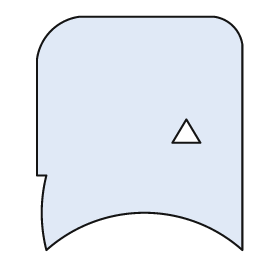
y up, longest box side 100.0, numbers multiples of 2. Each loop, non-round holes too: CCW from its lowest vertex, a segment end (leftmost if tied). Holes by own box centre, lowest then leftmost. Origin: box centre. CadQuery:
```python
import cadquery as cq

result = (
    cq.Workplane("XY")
    .moveTo(-40.0, -50.0)
    .threePointArc((2.0, -34.0), (44.0, -50.0))
    .lineTo(44.0, 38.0)
    .threePointArc((40.0, 46.0), (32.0, 50.0))
    .lineTo(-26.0, 50.0)
    .threePointArc((-38.0, 44.0), (-44.0, 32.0))
    .lineTo(-44.0, -18.0)
    .lineTo(-40.0, -18.0)
    .threePointArc((-42.0, -34.0), (-40.0, -50.0))
    .close()
    .moveTo(14.0, -4.0)
    .lineTo(26.0, -4.0)
    .lineTo(20.0, 6.0)
    .close()
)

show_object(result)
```